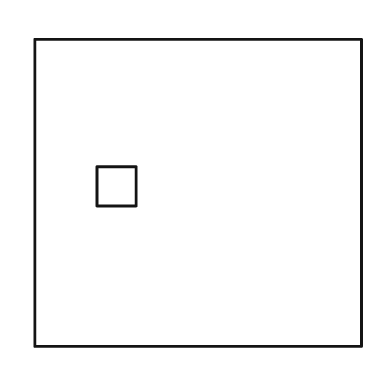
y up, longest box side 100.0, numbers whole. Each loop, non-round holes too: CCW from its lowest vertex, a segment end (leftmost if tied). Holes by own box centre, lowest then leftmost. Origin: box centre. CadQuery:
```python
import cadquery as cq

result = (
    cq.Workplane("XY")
    .moveTo(-50.0, -47.0)
    .lineTo(50.0, -47.0)
    .lineTo(50.0, 47.0)
    .lineTo(-50.0, 47.0)
    .close()
    .moveTo(-31.0, -4.0)
    .lineTo(-19.0, -4.0)
    .lineTo(-19.0, 8.0)
    .lineTo(-31.0, 8.0)
    .close()
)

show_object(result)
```